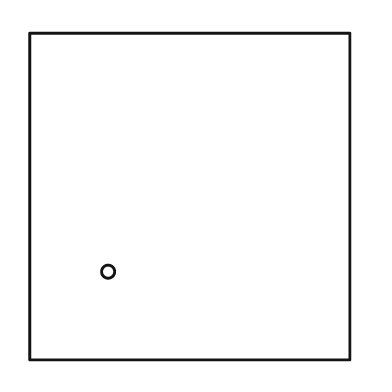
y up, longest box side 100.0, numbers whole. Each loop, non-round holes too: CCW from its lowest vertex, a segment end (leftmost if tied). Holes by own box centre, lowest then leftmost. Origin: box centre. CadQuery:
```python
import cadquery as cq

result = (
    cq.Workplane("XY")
    .moveTo(-49.0, -50.0)
    .lineTo(49.0, -50.0)
    .lineTo(49.0, 50.0)
    .lineTo(-49.0, 50.0)
    .close()
    .moveTo(-25.0, -23.0)
    .circle(2.0)
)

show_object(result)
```